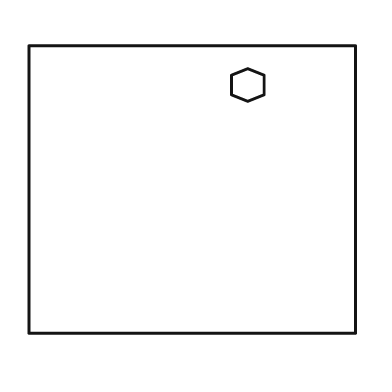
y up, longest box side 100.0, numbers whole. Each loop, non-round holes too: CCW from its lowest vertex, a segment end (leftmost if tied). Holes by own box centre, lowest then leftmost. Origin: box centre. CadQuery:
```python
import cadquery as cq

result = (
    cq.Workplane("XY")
    .moveTo(-50.0, -44.0)
    .lineTo(50.0, -44.0)
    .lineTo(50.0, 44.0)
    .lineTo(-50.0, 44.0)
    .close()
    .moveTo(17.0, 27.0)
    .lineTo(22.0, 29.0)
    .lineTo(22.0, 35.0)
    .lineTo(17.0, 37.0)
    .lineTo(12.0, 35.0)
    .lineTo(12.0, 29.0)
    .close()
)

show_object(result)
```